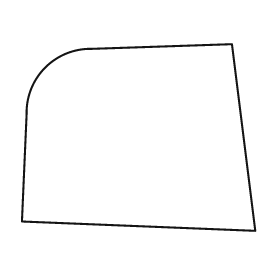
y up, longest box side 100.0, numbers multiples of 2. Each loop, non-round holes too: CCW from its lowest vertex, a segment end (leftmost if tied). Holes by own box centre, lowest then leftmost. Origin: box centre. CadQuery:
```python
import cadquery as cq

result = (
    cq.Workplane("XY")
    .moveTo(50.0, -40.0)
    .lineTo(40.0, 40.0)
    .lineTo(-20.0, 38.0)
    .threePointArc((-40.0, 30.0), (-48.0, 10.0))
    .lineTo(-50.0, -36.0)
    .close()
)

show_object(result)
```